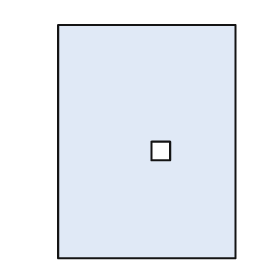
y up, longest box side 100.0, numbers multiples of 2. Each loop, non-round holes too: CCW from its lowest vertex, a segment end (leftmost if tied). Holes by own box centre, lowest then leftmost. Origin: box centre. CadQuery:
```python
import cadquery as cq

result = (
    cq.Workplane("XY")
    .moveTo(-38.0, -50.0)
    .lineTo(38.0, -50.0)
    .lineTo(38.0, 50.0)
    .lineTo(-38.0, 50.0)
    .close()
    .moveTo(2.0, -8.0)
    .lineTo(10.0, -8.0)
    .lineTo(10.0, 0.0)
    .lineTo(2.0, 0.0)
    .close()
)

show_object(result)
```